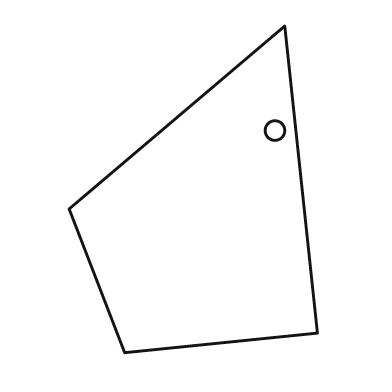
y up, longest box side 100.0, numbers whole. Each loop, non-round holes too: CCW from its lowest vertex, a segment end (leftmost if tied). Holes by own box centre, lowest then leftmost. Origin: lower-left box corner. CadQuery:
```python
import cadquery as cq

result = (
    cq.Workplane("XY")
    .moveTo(17.0, 0.0)
    .lineTo(76.0, 6.0)
    .lineTo(66.0, 100.0)
    .lineTo(0.0, 44.0)
    .close()
    .moveTo(63.0, 68.0)
    .circle(3.0)
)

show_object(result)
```